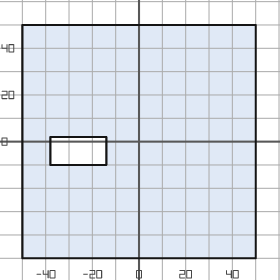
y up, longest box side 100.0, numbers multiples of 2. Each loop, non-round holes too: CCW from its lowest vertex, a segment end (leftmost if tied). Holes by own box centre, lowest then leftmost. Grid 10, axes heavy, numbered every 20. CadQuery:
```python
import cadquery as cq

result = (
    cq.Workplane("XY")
    .moveTo(-50.0, -50.0)
    .lineTo(50.0, -50.0)
    .lineTo(50.0, 50.0)
    .lineTo(-50.0, 50.0)
    .close()
    .moveTo(-38.0, -10.0)
    .lineTo(-14.0, -10.0)
    .lineTo(-14.0, 2.0)
    .lineTo(-38.0, 2.0)
    .close()
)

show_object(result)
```